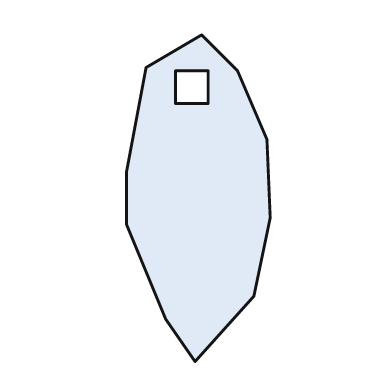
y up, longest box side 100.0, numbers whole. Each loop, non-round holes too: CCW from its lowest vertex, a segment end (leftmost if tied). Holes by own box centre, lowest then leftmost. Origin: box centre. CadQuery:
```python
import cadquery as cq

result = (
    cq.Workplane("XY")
    .moveTo(-1.0, -50.0)
    .lineTo(17.0, -30.0)
    .lineTo(22.0, -6.0)
    .lineTo(21.0, 18.0)
    .lineTo(12.0, 39.0)
    .lineTo(1.0, 50.0)
    .lineTo(-16.0, 40.0)
    .lineTo(-22.0, 8.0)
    .lineTo(-22.0, -8.0)
    .lineTo(-10.0, -37.0)
    .close()
    .moveTo(-7.0, 29.0)
    .lineTo(3.0, 29.0)
    .lineTo(3.0, 39.0)
    .lineTo(-7.0, 39.0)
    .close()
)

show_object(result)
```